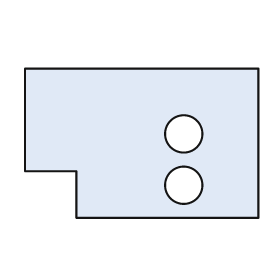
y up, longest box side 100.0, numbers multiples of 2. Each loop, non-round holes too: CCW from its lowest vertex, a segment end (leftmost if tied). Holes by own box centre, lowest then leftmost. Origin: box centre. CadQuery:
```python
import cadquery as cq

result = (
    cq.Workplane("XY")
    .moveTo(-28.0, -32.0)
    .lineTo(50.0, -32.0)
    .lineTo(50.0, 32.0)
    .lineTo(-50.0, 32.0)
    .lineTo(-50.0, -12.0)
    .lineTo(-28.0, -12.0)
    .close()
    .moveTo(18.0, -18.0)
    .circle(8.0)
    .moveTo(18.0, 4.0)
    .circle(8.0)
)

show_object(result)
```